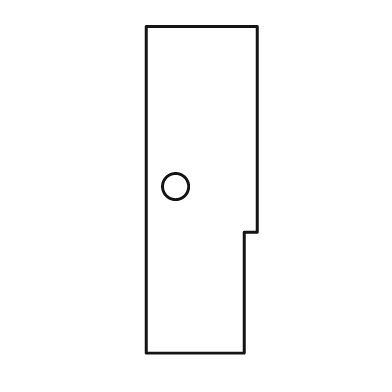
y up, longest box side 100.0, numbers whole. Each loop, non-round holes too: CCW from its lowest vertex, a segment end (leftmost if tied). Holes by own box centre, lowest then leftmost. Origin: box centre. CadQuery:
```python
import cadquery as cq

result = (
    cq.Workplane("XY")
    .moveTo(-17.0, -50.0)
    .lineTo(13.0, -50.0)
    .lineTo(13.0, -13.0)
    .lineTo(17.0, -13.0)
    .lineTo(17.0, 50.0)
    .lineTo(-17.0, 50.0)
    .close()
    .moveTo(-8.0, 1.0)
    .circle(4.0)
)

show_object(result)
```